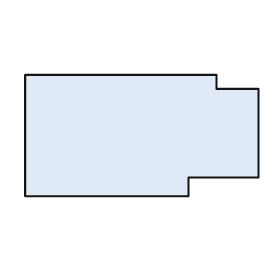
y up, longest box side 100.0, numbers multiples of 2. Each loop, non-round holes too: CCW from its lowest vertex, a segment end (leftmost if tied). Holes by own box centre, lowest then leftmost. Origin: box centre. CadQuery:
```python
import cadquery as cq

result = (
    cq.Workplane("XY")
    .moveTo(-50.0, -26.0)
    .lineTo(20.0, -26.0)
    .lineTo(20.0, -18.0)
    .lineTo(50.0, -18.0)
    .lineTo(50.0, 20.0)
    .lineTo(32.0, 20.0)
    .lineTo(32.0, 26.0)
    .lineTo(-50.0, 26.0)
    .close()
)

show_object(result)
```